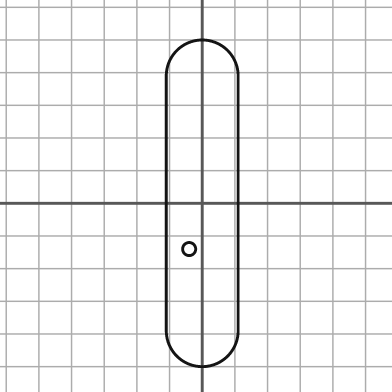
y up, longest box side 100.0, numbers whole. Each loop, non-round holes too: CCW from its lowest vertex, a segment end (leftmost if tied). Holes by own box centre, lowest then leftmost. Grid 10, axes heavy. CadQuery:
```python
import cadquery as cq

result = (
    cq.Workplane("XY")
    .moveTo(-11.0, -39.0)
    .threePointArc((0.0, -50.0), (11.0, -39.0))
    .lineTo(11.0, 39.0)
    .threePointArc((0.0, 50.0), (-11.0, 39.0))
    .close()
    .moveTo(-4.0, -14.0)
    .circle(2.0)
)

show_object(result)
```